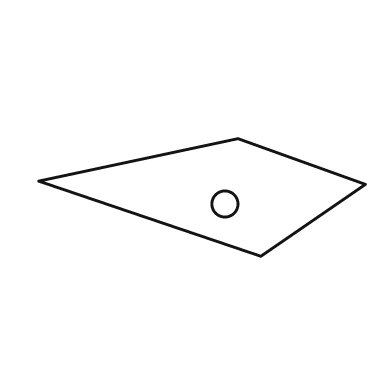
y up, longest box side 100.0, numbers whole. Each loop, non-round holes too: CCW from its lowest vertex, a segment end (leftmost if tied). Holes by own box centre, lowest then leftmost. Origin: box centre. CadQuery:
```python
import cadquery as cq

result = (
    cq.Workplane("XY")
    .moveTo(18.0, -18.0)
    .lineTo(50.0, 4.0)
    .lineTo(11.0, 18.0)
    .lineTo(-50.0, 5.0)
    .close()
    .moveTo(7.0, -2.0)
    .circle(4.0)
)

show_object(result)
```